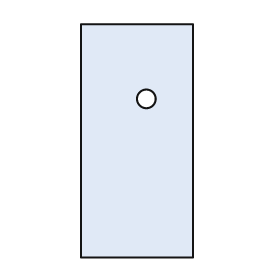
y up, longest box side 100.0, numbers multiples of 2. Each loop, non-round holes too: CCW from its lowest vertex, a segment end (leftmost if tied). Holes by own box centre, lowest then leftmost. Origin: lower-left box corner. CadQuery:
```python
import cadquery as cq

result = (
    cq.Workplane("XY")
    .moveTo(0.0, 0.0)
    .lineTo(48.0, 0.0)
    .lineTo(48.0, 100.0)
    .lineTo(0.0, 100.0)
    .close()
    .moveTo(28.0, 68.0)
    .circle(4.0)
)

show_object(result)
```